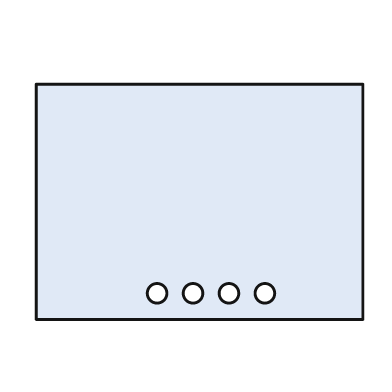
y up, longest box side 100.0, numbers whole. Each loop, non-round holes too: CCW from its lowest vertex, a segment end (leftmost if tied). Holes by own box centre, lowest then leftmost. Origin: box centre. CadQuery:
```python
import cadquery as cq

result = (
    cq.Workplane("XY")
    .moveTo(-50.0, -36.0)
    .lineTo(50.0, -36.0)
    .lineTo(50.0, 36.0)
    .lineTo(-50.0, 36.0)
    .close()
    .moveTo(-13.0, -28.0)
    .circle(3.0)
    .moveTo(-2.0, -28.0)
    .circle(3.0)
    .moveTo(9.0, -28.0)
    .circle(3.0)
    .moveTo(20.0, -28.0)
    .circle(3.0)
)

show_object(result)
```